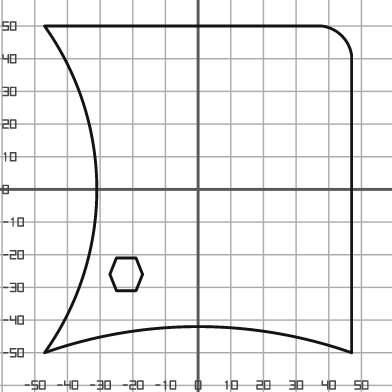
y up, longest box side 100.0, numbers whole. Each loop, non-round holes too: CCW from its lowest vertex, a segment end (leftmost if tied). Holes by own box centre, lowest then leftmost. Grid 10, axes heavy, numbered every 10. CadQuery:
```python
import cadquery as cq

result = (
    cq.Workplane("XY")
    .moveTo(-47.0, -50.0)
    .threePointArc((0.0, -42.0), (47.0, -50.0))
    .lineTo(47.0, 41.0)
    .threePointArc((44.0, 47.0), (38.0, 50.0))
    .lineTo(-47.0, 50.0)
    .threePointArc((-31.0, 0.0), (-47.0, -50.0))
    .close()
    .moveTo(-25.0, -31.0)
    .lineTo(-19.0, -31.0)
    .lineTo(-17.0, -26.0)
    .lineTo(-19.0, -21.0)
    .lineTo(-25.0, -21.0)
    .lineTo(-27.0, -26.0)
    .close()
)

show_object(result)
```